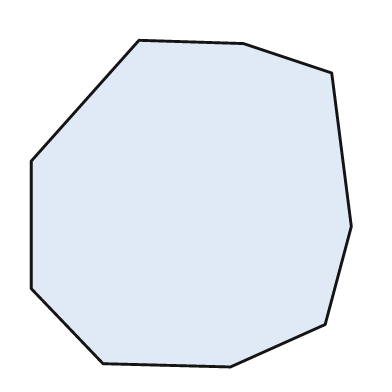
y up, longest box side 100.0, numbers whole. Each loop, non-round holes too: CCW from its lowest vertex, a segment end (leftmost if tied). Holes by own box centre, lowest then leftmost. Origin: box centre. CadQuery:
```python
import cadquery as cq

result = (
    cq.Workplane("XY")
    .moveTo(12.0, -50.0)
    .lineTo(41.0, -37.0)
    .lineTo(49.0, -7.0)
    .lineTo(43.0, 40.0)
    .lineTo(16.0, 49.0)
    .lineTo(-16.0, 50.0)
    .lineTo(-49.0, 13.0)
    .lineTo(-49.0, -26.0)
    .lineTo(-27.0, -49.0)
    .close()
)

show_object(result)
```